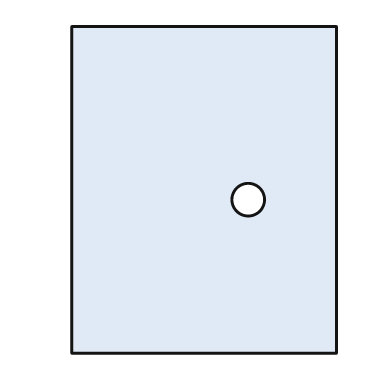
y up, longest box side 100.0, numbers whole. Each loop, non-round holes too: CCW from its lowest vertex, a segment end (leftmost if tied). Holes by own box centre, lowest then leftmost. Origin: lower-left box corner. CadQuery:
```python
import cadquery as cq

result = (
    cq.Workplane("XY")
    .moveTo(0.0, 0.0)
    .lineTo(81.0, 0.0)
    .lineTo(81.0, 100.0)
    .lineTo(0.0, 100.0)
    .close()
    .moveTo(54.0, 47.0)
    .circle(5.0)
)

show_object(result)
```